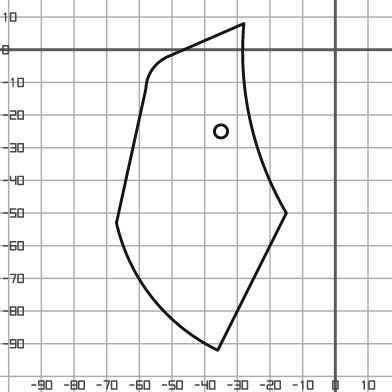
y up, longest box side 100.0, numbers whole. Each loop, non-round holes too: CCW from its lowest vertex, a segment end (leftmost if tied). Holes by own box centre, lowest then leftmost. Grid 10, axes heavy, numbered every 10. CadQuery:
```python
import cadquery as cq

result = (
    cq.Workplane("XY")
    .moveTo(-36.0, -92.0)
    .lineTo(-15.0, -50.0)
    .threePointArc((-26.0, -22.0), (-28.0, 8.0))
    .lineTo(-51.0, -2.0)
    .threePointArc((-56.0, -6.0), (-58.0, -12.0))
    .lineTo(-67.0, -53.0)
    .threePointArc((-56.0, -76.0), (-36.0, -92.0))
    .close()
    .moveTo(-35.0, -25.0)
    .circle(2.0)
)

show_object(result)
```